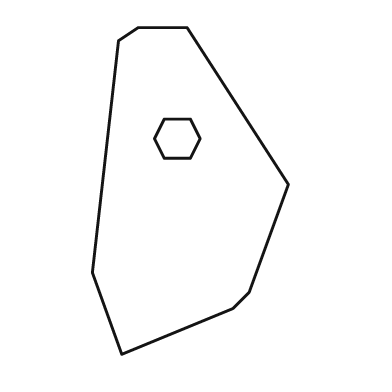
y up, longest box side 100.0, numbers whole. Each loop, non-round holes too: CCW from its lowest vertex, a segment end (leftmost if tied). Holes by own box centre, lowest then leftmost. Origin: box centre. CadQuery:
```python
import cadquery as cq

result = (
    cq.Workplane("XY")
    .moveTo(-21.0, -50.0)
    .lineTo(13.0, -36.0)
    .lineTo(18.0, -31.0)
    .lineTo(30.0, 2.0)
    .lineTo(-1.0, 50.0)
    .lineTo(-16.0, 50.0)
    .lineTo(-22.0, 46.0)
    .lineTo(-30.0, -25.0)
    .close()
    .moveTo(-8.0, 10.0)
    .lineTo(0.0, 10.0)
    .lineTo(3.0, 16.0)
    .lineTo(0.0, 22.0)
    .lineTo(-8.0, 22.0)
    .lineTo(-11.0, 16.0)
    .close()
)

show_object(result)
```